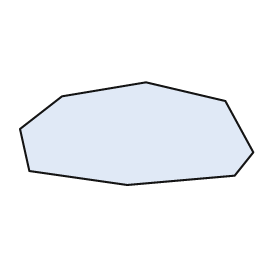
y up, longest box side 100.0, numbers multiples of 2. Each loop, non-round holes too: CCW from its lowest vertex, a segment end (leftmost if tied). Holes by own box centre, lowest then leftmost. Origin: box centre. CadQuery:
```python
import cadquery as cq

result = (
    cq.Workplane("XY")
    .moveTo(-4.0, -22.0)
    .lineTo(42.0, -18.0)
    .lineTo(50.0, -8.0)
    .lineTo(38.0, 14.0)
    .lineTo(4.0, 22.0)
    .lineTo(-32.0, 16.0)
    .lineTo(-50.0, 2.0)
    .lineTo(-46.0, -16.0)
    .close()
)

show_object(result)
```